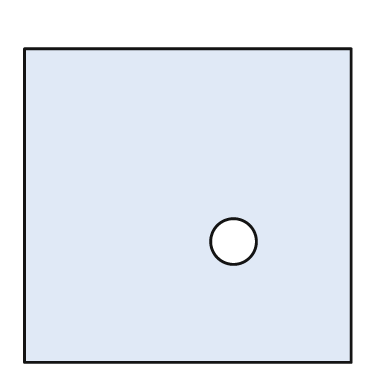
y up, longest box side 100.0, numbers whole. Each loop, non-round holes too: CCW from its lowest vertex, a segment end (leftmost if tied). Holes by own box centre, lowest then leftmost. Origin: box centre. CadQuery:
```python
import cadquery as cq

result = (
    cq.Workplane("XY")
    .moveTo(-50.0, -48.0)
    .lineTo(50.0, -48.0)
    .lineTo(50.0, 48.0)
    .lineTo(-50.0, 48.0)
    .close()
    .moveTo(14.0, -11.0)
    .circle(7.0)
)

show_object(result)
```